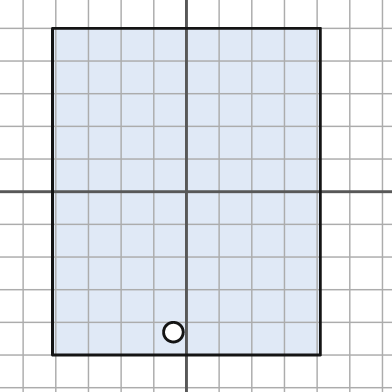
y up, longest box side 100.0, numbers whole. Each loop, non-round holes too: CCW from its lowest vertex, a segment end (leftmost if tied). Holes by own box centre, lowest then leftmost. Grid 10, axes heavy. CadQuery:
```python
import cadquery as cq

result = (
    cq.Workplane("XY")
    .moveTo(-41.0, -50.0)
    .lineTo(41.0, -50.0)
    .lineTo(41.0, 50.0)
    .lineTo(-41.0, 50.0)
    .close()
    .moveTo(-4.0, -43.0)
    .circle(3.0)
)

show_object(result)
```